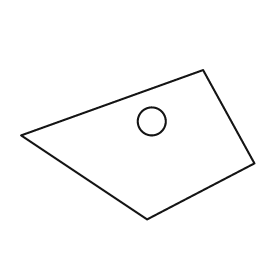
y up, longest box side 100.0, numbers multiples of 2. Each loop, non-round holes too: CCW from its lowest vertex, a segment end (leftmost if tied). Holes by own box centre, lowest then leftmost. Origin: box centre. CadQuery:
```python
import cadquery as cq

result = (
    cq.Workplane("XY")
    .moveTo(4.0, -32.0)
    .lineTo(50.0, -8.0)
    .lineTo(28.0, 32.0)
    .lineTo(-50.0, 4.0)
    .close()
    .moveTo(6.0, 10.0)
    .circle(6.0)
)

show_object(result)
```